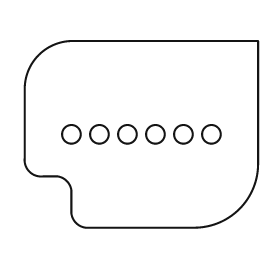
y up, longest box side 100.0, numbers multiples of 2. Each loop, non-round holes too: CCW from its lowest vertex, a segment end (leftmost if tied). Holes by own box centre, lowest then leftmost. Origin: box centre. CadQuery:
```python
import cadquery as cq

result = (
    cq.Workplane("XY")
    .moveTo(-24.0, -40.0)
    .lineTo(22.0, -40.0)
    .threePointArc((42.0, -32.0), (50.0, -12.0))
    .lineTo(50.0, 40.0)
    .lineTo(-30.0, 40.0)
    .threePointArc((-44.0, 34.0), (-50.0, 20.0))
    .lineTo(-50.0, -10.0)
    .threePointArc((-48.0, -16.0), (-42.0, -18.0))
    .lineTo(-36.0, -18.0)
    .threePointArc((-32.0, -20.0), (-30.0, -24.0))
    .lineTo(-30.0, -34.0)
    .threePointArc((-28.0, -38.0), (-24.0, -40.0))
    .close()
    .moveTo(-30.0, 0.0)
    .circle(4.0)
    .moveTo(-18.0, 0.0)
    .circle(4.0)
    .moveTo(-6.0, 0.0)
    .circle(4.0)
    .moveTo(6.0, 0.0)
    .circle(4.0)
    .moveTo(18.0, 0.0)
    .circle(4.0)
    .moveTo(30.0, 0.0)
    .circle(4.0)
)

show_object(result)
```